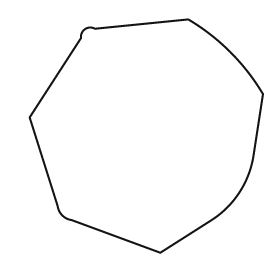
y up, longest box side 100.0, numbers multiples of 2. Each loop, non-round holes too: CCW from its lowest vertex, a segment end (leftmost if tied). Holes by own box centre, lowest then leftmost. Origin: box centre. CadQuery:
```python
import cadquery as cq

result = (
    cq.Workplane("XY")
    .moveTo(6.0, -50.0)
    .lineTo(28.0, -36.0)
    .threePointArc((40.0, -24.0), (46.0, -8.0))
    .lineTo(50.0, 18.0)
    .threePointArc((36.0, 36.0), (18.0, 50.0))
    .lineTo(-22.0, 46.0)
    .threePointArc((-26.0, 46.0), (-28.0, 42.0))
    .lineTo(-50.0, 8.0)
    .lineTo(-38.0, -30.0)
    .threePointArc((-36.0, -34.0), (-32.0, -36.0))
    .close()
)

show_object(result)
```